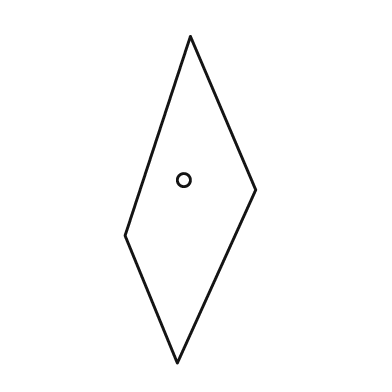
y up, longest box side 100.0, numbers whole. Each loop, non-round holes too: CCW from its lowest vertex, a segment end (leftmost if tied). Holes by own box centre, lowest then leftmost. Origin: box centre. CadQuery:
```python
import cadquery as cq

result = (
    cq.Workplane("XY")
    .moveTo(-4.0, -50.0)
    .lineTo(20.0, 3.0)
    .lineTo(0.0, 50.0)
    .lineTo(-20.0, -11.0)
    .close()
    .moveTo(-2.0, 6.0)
    .circle(2.0)
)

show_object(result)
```